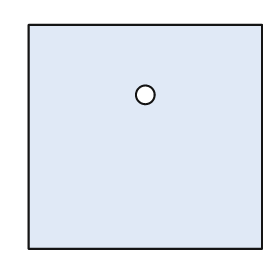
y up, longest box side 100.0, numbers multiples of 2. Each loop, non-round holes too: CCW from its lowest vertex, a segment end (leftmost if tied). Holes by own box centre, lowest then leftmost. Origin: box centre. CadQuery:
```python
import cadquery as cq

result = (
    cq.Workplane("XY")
    .moveTo(-50.0, -48.0)
    .lineTo(50.0, -48.0)
    .lineTo(50.0, 48.0)
    .lineTo(-50.0, 48.0)
    .close()
    .moveTo(0.0, 18.0)
    .circle(4.0)
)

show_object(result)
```